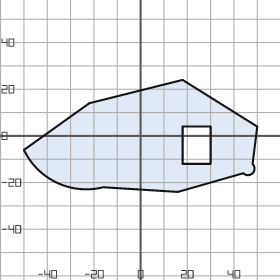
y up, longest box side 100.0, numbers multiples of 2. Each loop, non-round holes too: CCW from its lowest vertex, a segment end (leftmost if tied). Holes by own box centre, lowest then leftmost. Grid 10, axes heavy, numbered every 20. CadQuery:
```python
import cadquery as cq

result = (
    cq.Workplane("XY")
    .moveTo(16.0, -24.0)
    .lineTo(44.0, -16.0)
    .threePointArc((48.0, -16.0), (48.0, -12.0))
    .lineTo(50.0, 4.0)
    .lineTo(18.0, 24.0)
    .lineTo(-22.0, 14.0)
    .lineTo(-50.0, -6.0)
    .threePointArc((-36.0, -20.0), (-16.0, -22.0))
    .close()
    .moveTo(18.0, -12.0)
    .lineTo(30.0, -12.0)
    .lineTo(30.0, 4.0)
    .lineTo(18.0, 4.0)
    .close()
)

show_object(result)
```